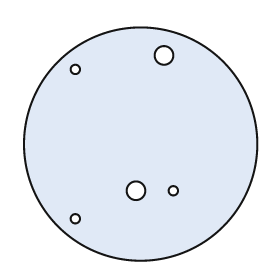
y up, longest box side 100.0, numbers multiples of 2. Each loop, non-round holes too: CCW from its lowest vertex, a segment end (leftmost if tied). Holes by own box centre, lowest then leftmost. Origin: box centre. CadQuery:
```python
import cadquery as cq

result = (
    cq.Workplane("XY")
    .moveTo(0.0, 0.0)
    .circle(50.0)
    .moveTo(-28.0, -32.0)
    .circle(2.0)
    .moveTo(-2.0, -20.0)
    .circle(4.0)
    .moveTo(14.0, -20.0)
    .circle(2.0)
    .moveTo(-28.0, 32.0)
    .circle(2.0)
    .moveTo(10.0, 38.0)
    .circle(4.0)
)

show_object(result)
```